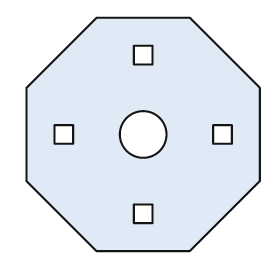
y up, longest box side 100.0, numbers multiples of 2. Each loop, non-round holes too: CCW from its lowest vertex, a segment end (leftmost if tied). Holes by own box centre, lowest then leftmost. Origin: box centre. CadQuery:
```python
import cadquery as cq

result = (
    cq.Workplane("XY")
    .moveTo(-20.0, -50.0)
    .lineTo(20.0, -50.0)
    .lineTo(50.0, -20.0)
    .lineTo(50.0, 20.0)
    .lineTo(20.0, 50.0)
    .lineTo(-20.0, 50.0)
    .lineTo(-50.0, 20.0)
    .lineTo(-50.0, -20.0)
    .close()
    .moveTo(-4.0, -38.0)
    .lineTo(4.0, -38.0)
    .lineTo(4.0, -30.0)
    .lineTo(-4.0, -30.0)
    .close()
    .moveTo(-38.0, -4.0)
    .lineTo(-30.0, -4.0)
    .lineTo(-30.0, 4.0)
    .lineTo(-38.0, 4.0)
    .close()
    .moveTo(0.0, 0.0)
    .circle(10.0)
    .moveTo(30.0, -4.0)
    .lineTo(38.0, -4.0)
    .lineTo(38.0, 4.0)
    .lineTo(30.0, 4.0)
    .close()
    .moveTo(-4.0, 30.0)
    .lineTo(4.0, 30.0)
    .lineTo(4.0, 38.0)
    .lineTo(-4.0, 38.0)
    .close()
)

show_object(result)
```